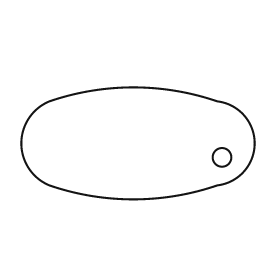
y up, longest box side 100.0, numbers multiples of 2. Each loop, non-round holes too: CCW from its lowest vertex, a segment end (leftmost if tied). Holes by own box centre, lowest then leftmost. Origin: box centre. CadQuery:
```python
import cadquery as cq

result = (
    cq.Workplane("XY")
    .moveTo(-38.0, -18.0)
    .threePointArc((-2.0, -24.0), (34.0, -18.0))
    .threePointArc((50.0, 0.0), (34.0, 18.0))
    .threePointArc((-2.0, 24.0), (-38.0, 18.0))
    .threePointArc((-50.0, 0.0), (-38.0, -18.0))
    .close()
    .moveTo(36.0, -6.0)
    .circle(4.0)
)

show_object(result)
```